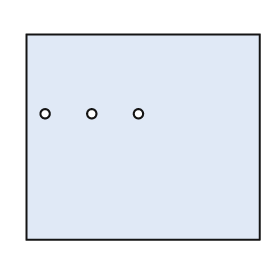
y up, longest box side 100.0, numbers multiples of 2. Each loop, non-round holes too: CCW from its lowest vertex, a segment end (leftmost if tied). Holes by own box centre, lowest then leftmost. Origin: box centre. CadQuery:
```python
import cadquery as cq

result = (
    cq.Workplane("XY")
    .moveTo(-50.0, -44.0)
    .lineTo(50.0, -44.0)
    .lineTo(50.0, 44.0)
    .lineTo(-50.0, 44.0)
    .close()
    .moveTo(-42.0, 10.0)
    .circle(2.0)
    .moveTo(-22.0, 10.0)
    .circle(2.0)
    .moveTo(-2.0, 10.0)
    .circle(2.0)
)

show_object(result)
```